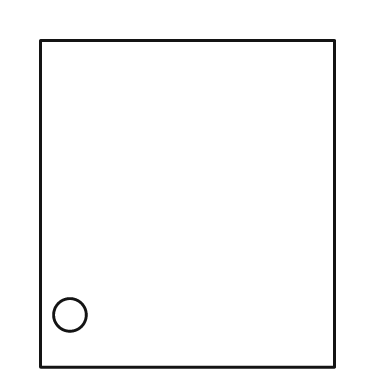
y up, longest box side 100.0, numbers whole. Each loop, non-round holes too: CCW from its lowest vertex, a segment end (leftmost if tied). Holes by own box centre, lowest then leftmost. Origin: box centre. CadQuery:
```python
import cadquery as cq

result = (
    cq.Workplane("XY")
    .moveTo(-45.0, -50.0)
    .lineTo(45.0, -50.0)
    .lineTo(45.0, 50.0)
    .lineTo(-45.0, 50.0)
    .close()
    .moveTo(-36.0, -34.0)
    .circle(5.0)
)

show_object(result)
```